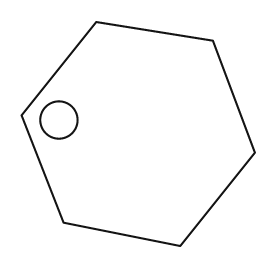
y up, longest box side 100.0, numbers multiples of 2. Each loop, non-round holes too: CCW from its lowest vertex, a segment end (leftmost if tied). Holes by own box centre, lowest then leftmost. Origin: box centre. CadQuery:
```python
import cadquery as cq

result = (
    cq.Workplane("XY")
    .moveTo(18.0, -48.0)
    .lineTo(50.0, -8.0)
    .lineTo(32.0, 40.0)
    .lineTo(-18.0, 48.0)
    .lineTo(-50.0, 8.0)
    .lineTo(-32.0, -38.0)
    .close()
    .moveTo(-34.0, 6.0)
    .circle(8.0)
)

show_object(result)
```